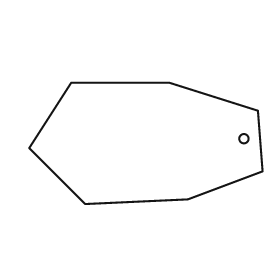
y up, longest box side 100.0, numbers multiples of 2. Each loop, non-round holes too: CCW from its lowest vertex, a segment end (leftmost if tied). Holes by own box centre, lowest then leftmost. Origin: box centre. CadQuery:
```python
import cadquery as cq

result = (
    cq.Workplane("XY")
    .moveTo(-26.0, -26.0)
    .lineTo(18.0, -24.0)
    .lineTo(50.0, -12.0)
    .lineTo(48.0, 14.0)
    .lineTo(10.0, 26.0)
    .lineTo(-32.0, 26.0)
    .lineTo(-50.0, -2.0)
    .close()
    .moveTo(42.0, 2.0)
    .circle(2.0)
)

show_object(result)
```